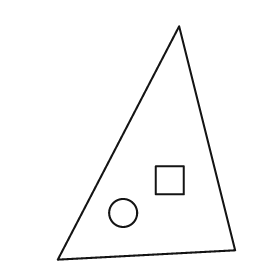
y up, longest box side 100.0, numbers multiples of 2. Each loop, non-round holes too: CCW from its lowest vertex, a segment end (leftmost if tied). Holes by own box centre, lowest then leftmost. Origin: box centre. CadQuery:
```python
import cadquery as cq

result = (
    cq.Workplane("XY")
    .moveTo(-38.0, -50.0)
    .lineTo(38.0, -46.0)
    .lineTo(14.0, 50.0)
    .close()
    .moveTo(-10.0, -30.0)
    .circle(6.0)
    .moveTo(4.0, -22.0)
    .lineTo(16.0, -22.0)
    .lineTo(16.0, -10.0)
    .lineTo(4.0, -10.0)
    .close()
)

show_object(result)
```